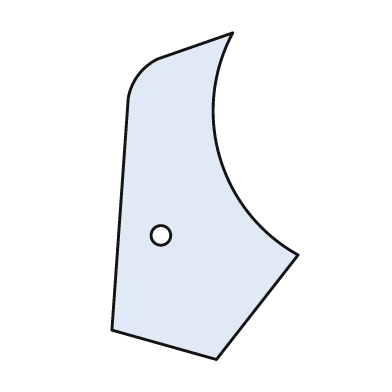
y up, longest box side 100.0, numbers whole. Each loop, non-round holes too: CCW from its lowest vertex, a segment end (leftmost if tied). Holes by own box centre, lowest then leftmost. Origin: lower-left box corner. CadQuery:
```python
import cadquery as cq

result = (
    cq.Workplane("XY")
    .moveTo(32.0, 0.0)
    .lineTo(57.0, 32.0)
    .threePointArc((33.0, 62.0), (37.0, 100.0))
    .lineTo(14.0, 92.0)
    .threePointArc((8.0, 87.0), (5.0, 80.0))
    .lineTo(0.0, 9.0)
    .close()
    .moveTo(15.0, 38.0)
    .circle(3.0)
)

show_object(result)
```